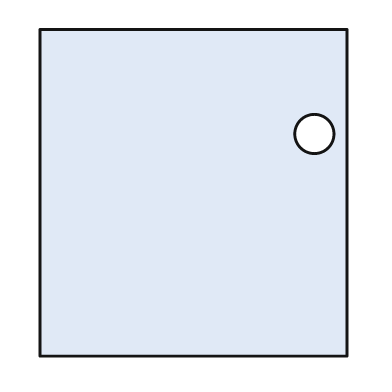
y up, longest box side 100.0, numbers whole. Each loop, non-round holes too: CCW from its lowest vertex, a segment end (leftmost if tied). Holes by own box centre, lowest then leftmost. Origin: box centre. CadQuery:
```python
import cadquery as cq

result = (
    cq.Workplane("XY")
    .moveTo(-47.0, -50.0)
    .lineTo(47.0, -50.0)
    .lineTo(47.0, 50.0)
    .lineTo(-47.0, 50.0)
    .close()
    .moveTo(37.0, 18.0)
    .circle(6.0)
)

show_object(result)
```